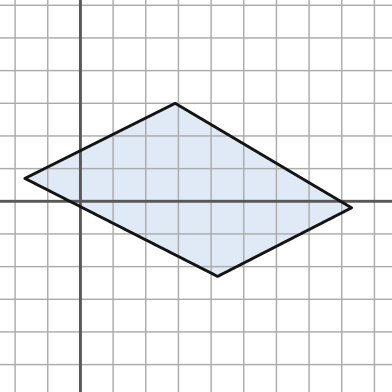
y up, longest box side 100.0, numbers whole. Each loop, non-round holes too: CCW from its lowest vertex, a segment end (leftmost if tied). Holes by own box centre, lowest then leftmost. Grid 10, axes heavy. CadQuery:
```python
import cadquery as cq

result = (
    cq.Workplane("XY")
    .moveTo(42.0, -23.0)
    .lineTo(83.0, -2.0)
    .lineTo(29.0, 30.0)
    .lineTo(-17.0, 7.0)
    .close()
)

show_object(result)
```